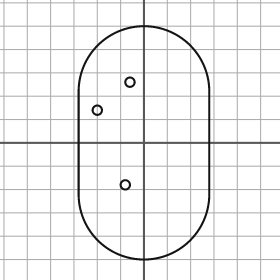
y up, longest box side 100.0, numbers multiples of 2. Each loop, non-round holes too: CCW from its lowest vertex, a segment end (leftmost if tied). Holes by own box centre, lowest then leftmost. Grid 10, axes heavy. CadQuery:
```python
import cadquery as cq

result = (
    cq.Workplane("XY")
    .moveTo(-28.0, -22.0)
    .threePointArc((0.0, -50.0), (28.0, -22.0))
    .lineTo(28.0, 22.0)
    .threePointArc((0.0, 50.0), (-28.0, 22.0))
    .close()
    .moveTo(-8.0, -18.0)
    .circle(2.0)
    .moveTo(-20.0, 14.0)
    .circle(2.0)
    .moveTo(-6.0, 26.0)
    .circle(2.0)
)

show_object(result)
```